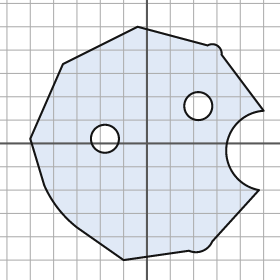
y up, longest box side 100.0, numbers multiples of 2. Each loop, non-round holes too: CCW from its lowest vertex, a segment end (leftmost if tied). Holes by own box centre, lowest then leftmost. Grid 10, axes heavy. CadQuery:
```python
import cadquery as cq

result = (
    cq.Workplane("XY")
    .moveTo(-10.0, -50.0)
    .lineTo(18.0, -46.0)
    .threePointArc((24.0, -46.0), (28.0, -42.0))
    .lineTo(48.0, -20.0)
    .threePointArc((34.0, -2.0), (50.0, 14.0))
    .lineTo(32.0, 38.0)
    .threePointArc((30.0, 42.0), (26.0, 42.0))
    .lineTo(-4.0, 50.0)
    .lineTo(-36.0, 34.0)
    .lineTo(-50.0, 2.0)
    .lineTo(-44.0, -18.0)
    .threePointArc((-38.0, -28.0), (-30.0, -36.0))
    .close()
    .moveTo(-18.0, 2.0)
    .circle(6.0)
    .moveTo(22.0, 16.0)
    .circle(6.0)
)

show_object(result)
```